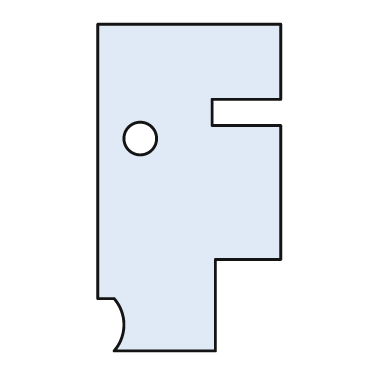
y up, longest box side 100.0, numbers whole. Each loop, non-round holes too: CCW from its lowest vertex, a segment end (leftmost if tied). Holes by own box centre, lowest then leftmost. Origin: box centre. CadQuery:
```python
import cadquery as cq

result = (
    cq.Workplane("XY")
    .moveTo(-23.0, -50.0)
    .lineTo(8.0, -50.0)
    .lineTo(8.0, -22.0)
    .lineTo(28.0, -22.0)
    .lineTo(28.0, 19.0)
    .lineTo(7.0, 19.0)
    .lineTo(7.0, 27.0)
    .lineTo(28.0, 27.0)
    .lineTo(28.0, 50.0)
    .lineTo(-28.0, 50.0)
    .lineTo(-28.0, -34.0)
    .lineTo(-23.0, -34.0)
    .threePointArc((-20.0, -42.0), (-23.0, -50.0))
    .close()
    .moveTo(-15.0, 15.0)
    .circle(5.0)
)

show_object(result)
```